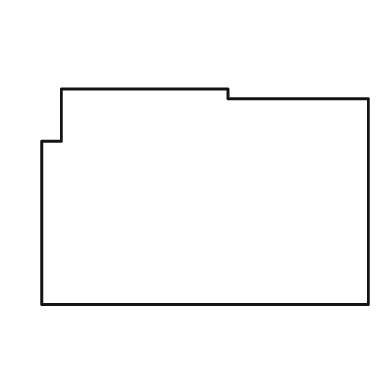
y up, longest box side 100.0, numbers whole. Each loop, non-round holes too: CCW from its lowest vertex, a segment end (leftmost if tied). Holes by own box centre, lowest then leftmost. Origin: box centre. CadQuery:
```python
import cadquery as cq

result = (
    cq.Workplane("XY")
    .moveTo(-50.0, -33.0)
    .lineTo(50.0, -33.0)
    .lineTo(50.0, 30.0)
    .lineTo(7.0, 30.0)
    .lineTo(7.0, 33.0)
    .lineTo(-44.0, 33.0)
    .lineTo(-44.0, 17.0)
    .lineTo(-50.0, 17.0)
    .close()
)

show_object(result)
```